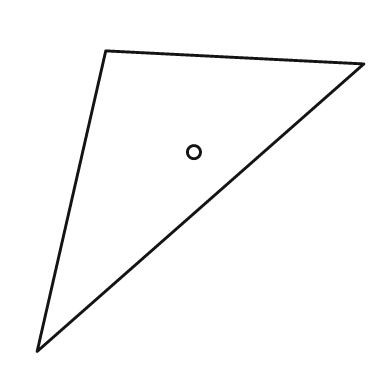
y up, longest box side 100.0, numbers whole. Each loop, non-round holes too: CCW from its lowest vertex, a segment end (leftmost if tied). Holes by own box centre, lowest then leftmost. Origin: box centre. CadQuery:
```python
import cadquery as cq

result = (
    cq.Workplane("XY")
    .moveTo(-50.0, -46.0)
    .lineTo(50.0, 42.0)
    .lineTo(-29.0, 46.0)
    .close()
    .moveTo(-2.0, 15.0)
    .circle(2.0)
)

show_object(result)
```